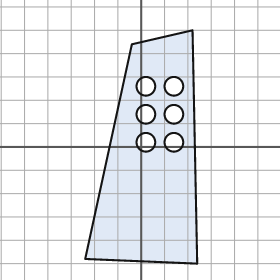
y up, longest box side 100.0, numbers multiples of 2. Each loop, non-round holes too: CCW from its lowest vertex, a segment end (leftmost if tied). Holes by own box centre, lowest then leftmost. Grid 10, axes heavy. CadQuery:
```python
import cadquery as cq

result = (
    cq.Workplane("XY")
    .moveTo(24.0, -50.0)
    .lineTo(22.0, 50.0)
    .lineTo(-4.0, 44.0)
    .lineTo(-24.0, -48.0)
    .close()
    .moveTo(2.0, 2.0)
    .circle(4.0)
    .moveTo(14.0, 2.0)
    .circle(4.0)
    .moveTo(2.0, 14.0)
    .circle(4.0)
    .moveTo(14.0, 14.0)
    .circle(4.0)
    .moveTo(2.0, 26.0)
    .circle(4.0)
    .moveTo(14.0, 26.0)
    .circle(4.0)
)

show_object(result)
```